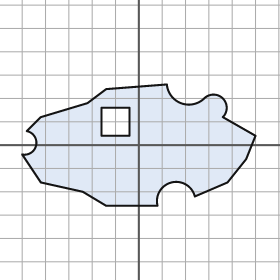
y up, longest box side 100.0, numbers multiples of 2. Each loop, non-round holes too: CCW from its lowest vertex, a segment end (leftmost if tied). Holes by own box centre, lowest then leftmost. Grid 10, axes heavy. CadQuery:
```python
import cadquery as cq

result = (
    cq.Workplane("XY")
    .moveTo(-14.0, -26.0)
    .lineTo(8.0, -26.0)
    .threePointArc((14.0, -16.0), (24.0, -22.0))
    .lineTo(38.0, -16.0)
    .lineTo(46.0, -6.0)
    .lineTo(50.0, 4.0)
    .lineTo(36.0, 12.0)
    .threePointArc((36.0, 20.0), (28.0, 20.0))
    .threePointArc((18.0, 18.0), (12.0, 26.0))
    .lineTo(-14.0, 24.0)
    .lineTo(-22.0, 18.0)
    .lineTo(-42.0, 12.0)
    .lineTo(-48.0, 6.0)
    .threePointArc((-44.0, 0.0), (-50.0, -4.0))
    .lineTo(-42.0, -16.0)
    .lineTo(-24.0, -20.0)
    .close()
    .moveTo(-16.0, 4.0)
    .lineTo(-4.0, 4.0)
    .lineTo(-4.0, 16.0)
    .lineTo(-16.0, 16.0)
    .close()
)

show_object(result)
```